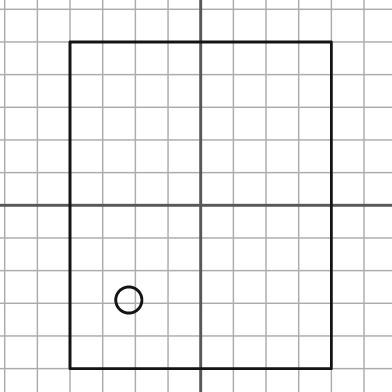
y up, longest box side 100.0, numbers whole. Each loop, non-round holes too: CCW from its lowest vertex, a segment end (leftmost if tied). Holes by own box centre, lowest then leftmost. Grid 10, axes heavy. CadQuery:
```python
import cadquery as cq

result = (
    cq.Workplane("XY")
    .moveTo(-40.0, -50.0)
    .lineTo(40.0, -50.0)
    .lineTo(40.0, 50.0)
    .lineTo(-40.0, 50.0)
    .close()
    .moveTo(-22.0, -29.0)
    .circle(4.0)
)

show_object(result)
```